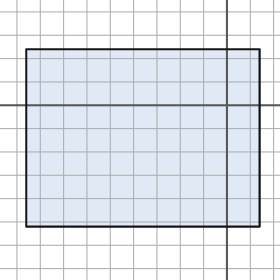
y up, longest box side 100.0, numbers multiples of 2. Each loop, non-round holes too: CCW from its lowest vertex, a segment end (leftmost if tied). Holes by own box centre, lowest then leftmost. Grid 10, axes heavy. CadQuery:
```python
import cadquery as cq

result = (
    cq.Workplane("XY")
    .moveTo(-86.0, -52.0)
    .lineTo(14.0, -52.0)
    .lineTo(14.0, 24.0)
    .lineTo(-86.0, 24.0)
    .close()
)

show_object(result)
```